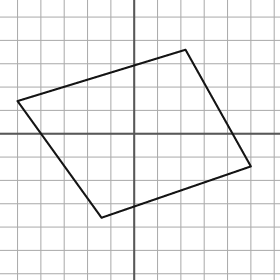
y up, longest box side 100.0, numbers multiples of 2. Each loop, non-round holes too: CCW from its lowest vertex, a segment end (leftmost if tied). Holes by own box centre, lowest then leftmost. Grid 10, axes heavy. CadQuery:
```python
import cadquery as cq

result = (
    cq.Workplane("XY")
    .moveTo(-14.0, -36.0)
    .lineTo(50.0, -14.0)
    .lineTo(22.0, 36.0)
    .lineTo(-50.0, 14.0)
    .close()
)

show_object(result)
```